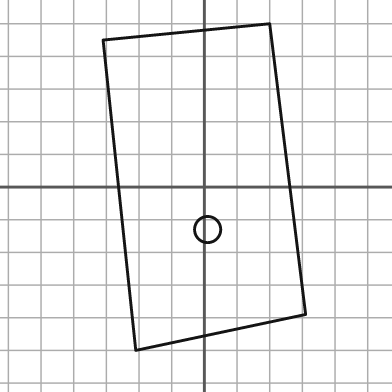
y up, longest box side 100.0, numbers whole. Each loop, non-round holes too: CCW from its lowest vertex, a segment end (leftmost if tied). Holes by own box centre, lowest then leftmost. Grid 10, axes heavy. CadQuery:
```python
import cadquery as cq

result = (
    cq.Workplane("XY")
    .moveTo(-21.0, -50.0)
    .lineTo(31.0, -39.0)
    .lineTo(20.0, 50.0)
    .lineTo(-31.0, 45.0)
    .close()
    .moveTo(1.0, -13.0)
    .circle(4.0)
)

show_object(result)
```